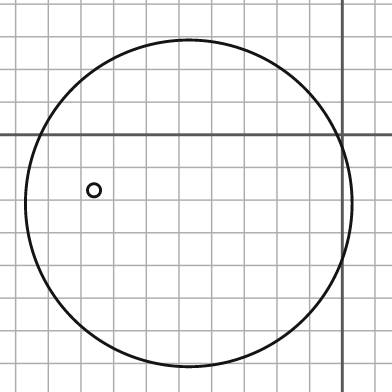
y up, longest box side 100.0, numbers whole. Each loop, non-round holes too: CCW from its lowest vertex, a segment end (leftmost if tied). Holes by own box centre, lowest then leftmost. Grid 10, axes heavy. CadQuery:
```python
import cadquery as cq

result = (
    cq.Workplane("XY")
    .moveTo(-47.0, -21.0)
    .circle(50.0)
    .moveTo(-76.0, -17.0)
    .circle(2.0)
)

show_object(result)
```